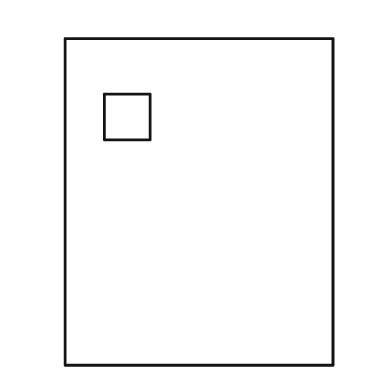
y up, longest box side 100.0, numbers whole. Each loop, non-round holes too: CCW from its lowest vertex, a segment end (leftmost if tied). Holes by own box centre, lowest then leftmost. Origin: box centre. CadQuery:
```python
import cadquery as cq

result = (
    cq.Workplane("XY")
    .moveTo(-41.0, -50.0)
    .lineTo(41.0, -50.0)
    .lineTo(41.0, 50.0)
    .lineTo(-41.0, 50.0)
    .close()
    .moveTo(-29.0, 19.0)
    .lineTo(-15.0, 19.0)
    .lineTo(-15.0, 33.0)
    .lineTo(-29.0, 33.0)
    .close()
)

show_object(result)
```